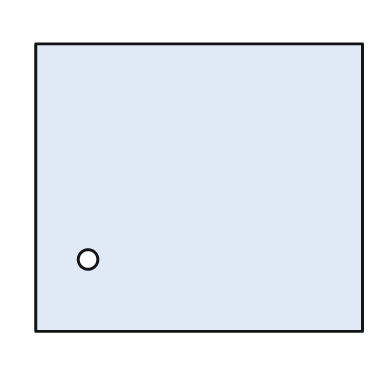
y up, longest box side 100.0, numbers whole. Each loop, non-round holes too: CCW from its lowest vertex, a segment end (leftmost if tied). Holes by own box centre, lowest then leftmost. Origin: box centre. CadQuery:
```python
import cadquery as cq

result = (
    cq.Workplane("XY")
    .moveTo(-50.0, -44.0)
    .lineTo(50.0, -44.0)
    .lineTo(50.0, 44.0)
    .lineTo(-50.0, 44.0)
    .close()
    .moveTo(-34.0, -22.0)
    .circle(3.0)
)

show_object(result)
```